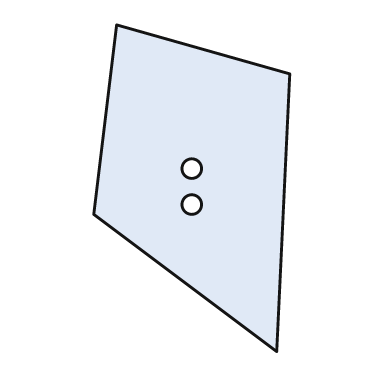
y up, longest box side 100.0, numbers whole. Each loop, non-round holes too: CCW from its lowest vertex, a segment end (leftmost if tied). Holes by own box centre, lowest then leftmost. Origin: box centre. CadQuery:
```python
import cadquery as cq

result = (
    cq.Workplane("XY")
    .moveTo(26.0, -50.0)
    .lineTo(30.0, 35.0)
    .lineTo(-23.0, 50.0)
    .lineTo(-30.0, -8.0)
    .close()
    .moveTo(0.0, -5.0)
    .circle(3.0)
    .moveTo(0.0, 6.0)
    .circle(3.0)
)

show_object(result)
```